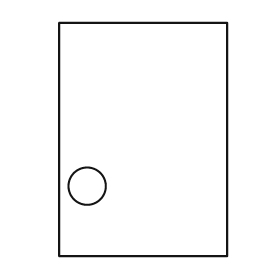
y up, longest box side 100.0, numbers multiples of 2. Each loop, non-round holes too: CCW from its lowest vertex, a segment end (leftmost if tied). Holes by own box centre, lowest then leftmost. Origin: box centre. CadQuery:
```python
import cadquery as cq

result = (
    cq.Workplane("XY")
    .moveTo(-36.0, -50.0)
    .lineTo(36.0, -50.0)
    .lineTo(36.0, 50.0)
    .lineTo(-36.0, 50.0)
    .close()
    .moveTo(-24.0, -20.0)
    .circle(8.0)
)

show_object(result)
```